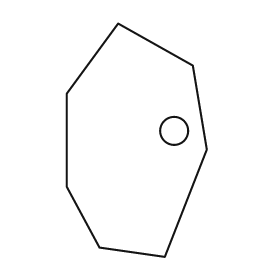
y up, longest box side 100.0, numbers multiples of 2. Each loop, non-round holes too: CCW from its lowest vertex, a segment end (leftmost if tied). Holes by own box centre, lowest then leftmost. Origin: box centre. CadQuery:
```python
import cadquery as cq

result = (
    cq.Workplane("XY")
    .moveTo(12.0, -50.0)
    .lineTo(30.0, -4.0)
    .lineTo(24.0, 32.0)
    .lineTo(-8.0, 50.0)
    .lineTo(-30.0, 20.0)
    .lineTo(-30.0, -20.0)
    .lineTo(-16.0, -46.0)
    .close()
    .moveTo(16.0, 4.0)
    .circle(6.0)
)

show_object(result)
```